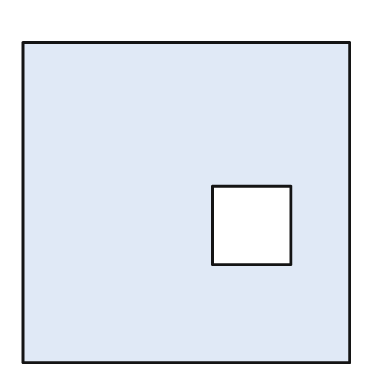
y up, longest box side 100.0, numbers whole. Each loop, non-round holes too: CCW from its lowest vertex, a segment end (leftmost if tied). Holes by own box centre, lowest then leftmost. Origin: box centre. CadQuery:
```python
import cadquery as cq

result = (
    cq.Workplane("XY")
    .moveTo(-50.0, -49.0)
    .lineTo(50.0, -49.0)
    .lineTo(50.0, 49.0)
    .lineTo(-50.0, 49.0)
    .close()
    .moveTo(8.0, -19.0)
    .lineTo(32.0, -19.0)
    .lineTo(32.0, 5.0)
    .lineTo(8.0, 5.0)
    .close()
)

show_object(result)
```